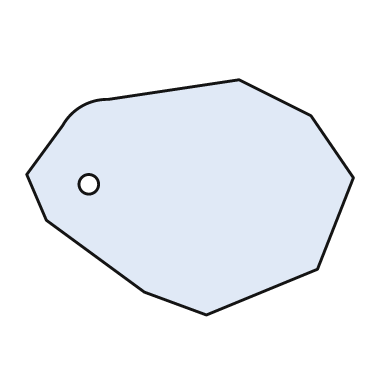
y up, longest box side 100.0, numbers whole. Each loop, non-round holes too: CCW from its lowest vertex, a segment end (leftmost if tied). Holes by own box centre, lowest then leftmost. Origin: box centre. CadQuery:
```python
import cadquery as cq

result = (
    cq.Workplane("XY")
    .moveTo(5.0, -36.0)
    .lineTo(39.0, -22.0)
    .lineTo(50.0, 6.0)
    .lineTo(37.0, 25.0)
    .lineTo(15.0, 36.0)
    .lineTo(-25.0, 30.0)
    .threePointArc((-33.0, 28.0), (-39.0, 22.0))
    .lineTo(-50.0, 7.0)
    .lineTo(-44.0, -7.0)
    .lineTo(-14.0, -29.0)
    .close()
    .moveTo(-31.0, 4.0)
    .circle(3.0)
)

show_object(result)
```